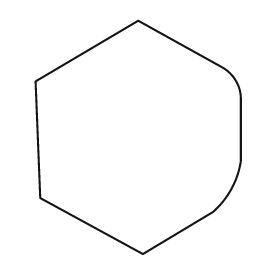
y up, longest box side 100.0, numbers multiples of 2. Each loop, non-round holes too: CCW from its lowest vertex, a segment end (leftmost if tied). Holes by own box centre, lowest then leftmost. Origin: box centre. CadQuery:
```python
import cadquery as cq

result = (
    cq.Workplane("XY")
    .moveTo(2.0, -50.0)
    .lineTo(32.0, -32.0)
    .threePointArc((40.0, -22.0), (44.0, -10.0))
    .lineTo(44.0, 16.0)
    .threePointArc((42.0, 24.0), (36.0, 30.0))
    .lineTo(0.0, 50.0)
    .lineTo(-44.0, 24.0)
    .lineTo(-42.0, -26.0)
    .close()
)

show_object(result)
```